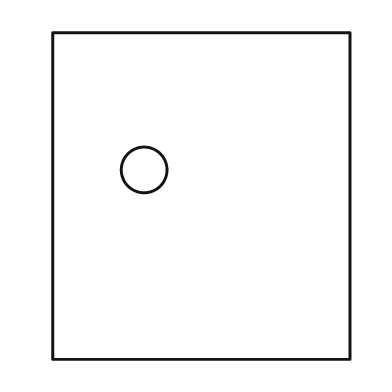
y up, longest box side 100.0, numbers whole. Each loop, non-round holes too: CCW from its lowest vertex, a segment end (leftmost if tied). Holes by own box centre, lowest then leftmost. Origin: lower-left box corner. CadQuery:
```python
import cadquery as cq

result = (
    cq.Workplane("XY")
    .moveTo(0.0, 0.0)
    .lineTo(91.0, 0.0)
    .lineTo(91.0, 100.0)
    .lineTo(0.0, 100.0)
    .close()
    .moveTo(28.0, 58.0)
    .circle(7.0)
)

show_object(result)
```